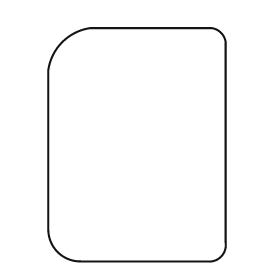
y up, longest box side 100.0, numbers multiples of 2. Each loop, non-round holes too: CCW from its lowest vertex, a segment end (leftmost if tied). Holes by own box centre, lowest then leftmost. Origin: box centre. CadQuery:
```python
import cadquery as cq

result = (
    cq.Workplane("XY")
    .moveTo(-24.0, -50.0)
    .lineTo(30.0, -50.0)
    .threePointArc((36.0, -48.0), (38.0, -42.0))
    .lineTo(38.0, 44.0)
    .threePointArc((36.0, 48.0), (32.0, 50.0))
    .lineTo(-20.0, 50.0)
    .threePointArc((-32.0, 44.0), (-38.0, 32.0))
    .lineTo(-38.0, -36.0)
    .threePointArc((-34.0, -46.0), (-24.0, -50.0))
    .close()
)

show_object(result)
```